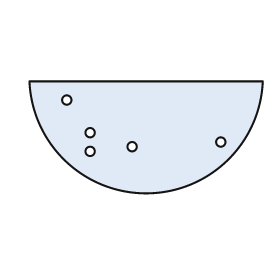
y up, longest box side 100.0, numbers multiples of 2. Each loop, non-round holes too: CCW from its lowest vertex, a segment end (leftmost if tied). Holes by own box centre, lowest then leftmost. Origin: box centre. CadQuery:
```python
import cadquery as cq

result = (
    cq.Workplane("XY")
    .moveTo(-50.0, 24.0)
    .threePointArc((0.0, -24.0), (50.0, 24.0))
    .close()
    .moveTo(-24.0, -6.0)
    .circle(2.0)
    .moveTo(-6.0, -4.0)
    .circle(2.0)
    .moveTo(32.0, -2.0)
    .circle(2.0)
    .moveTo(-24.0, 2.0)
    .circle(2.0)
    .moveTo(-34.0, 16.0)
    .circle(2.0)
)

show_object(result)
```